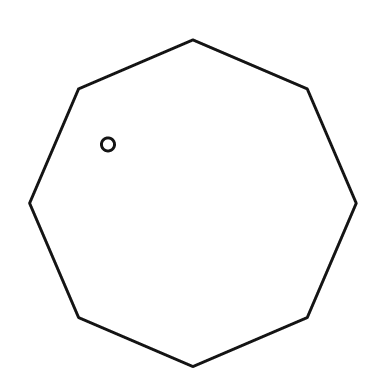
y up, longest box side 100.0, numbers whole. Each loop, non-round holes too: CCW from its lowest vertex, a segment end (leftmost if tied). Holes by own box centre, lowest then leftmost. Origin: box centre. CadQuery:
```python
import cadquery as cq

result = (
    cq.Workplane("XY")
    .moveTo(0.0, -50.0)
    .lineTo(35.0, -35.0)
    .lineTo(50.0, 0.0)
    .lineTo(35.0, 35.0)
    .lineTo(0.0, 50.0)
    .lineTo(-35.0, 35.0)
    .lineTo(-50.0, 0.0)
    .lineTo(-35.0, -35.0)
    .close()
    .moveTo(-26.0, 18.0)
    .circle(2.0)
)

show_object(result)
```